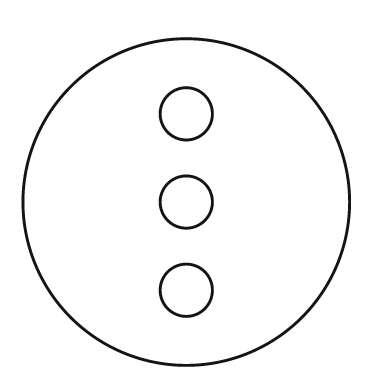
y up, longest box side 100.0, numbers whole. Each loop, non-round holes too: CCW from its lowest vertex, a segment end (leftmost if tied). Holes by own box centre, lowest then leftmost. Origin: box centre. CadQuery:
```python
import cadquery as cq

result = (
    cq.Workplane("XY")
    .moveTo(0.0, 0.0)
    .circle(50.0)
    .moveTo(0.0, -27.0)
    .circle(8.0)
    .moveTo(0.0, 0.0)
    .circle(8.0)
    .moveTo(0.0, 27.0)
    .circle(8.0)
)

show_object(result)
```